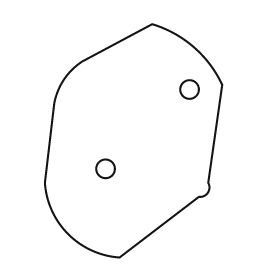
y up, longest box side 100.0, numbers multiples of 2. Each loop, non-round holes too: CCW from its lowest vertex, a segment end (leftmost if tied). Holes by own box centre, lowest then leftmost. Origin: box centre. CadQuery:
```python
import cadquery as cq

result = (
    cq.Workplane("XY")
    .moveTo(-6.0, -50.0)
    .lineTo(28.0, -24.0)
    .threePointArc((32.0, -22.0), (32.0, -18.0))
    .lineTo(38.0, 24.0)
    .threePointArc((26.0, 40.0), (8.0, 50.0))
    .lineTo(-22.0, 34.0)
    .threePointArc((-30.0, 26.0), (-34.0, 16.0))
    .lineTo(-38.0, -18.0)
    .threePointArc((-28.0, -40.0), (-6.0, -50.0))
    .close()
    .moveTo(-12.0, -12.0)
    .circle(4.0)
    .moveTo(24.0, 22.0)
    .circle(4.0)
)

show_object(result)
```